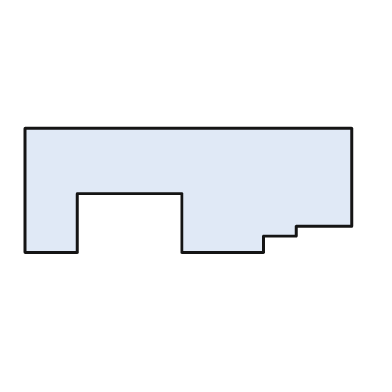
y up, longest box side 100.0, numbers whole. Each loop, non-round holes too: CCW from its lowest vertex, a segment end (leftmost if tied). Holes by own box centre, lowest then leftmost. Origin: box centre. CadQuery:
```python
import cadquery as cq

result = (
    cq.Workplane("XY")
    .moveTo(-50.0, -19.0)
    .lineTo(-34.0, -19.0)
    .lineTo(-34.0, -1.0)
    .lineTo(-2.0, -1.0)
    .lineTo(-2.0, -19.0)
    .lineTo(23.0, -19.0)
    .lineTo(23.0, -14.0)
    .lineTo(33.0, -14.0)
    .lineTo(33.0, -11.0)
    .lineTo(50.0, -11.0)
    .lineTo(50.0, 19.0)
    .lineTo(-50.0, 19.0)
    .close()
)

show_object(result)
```